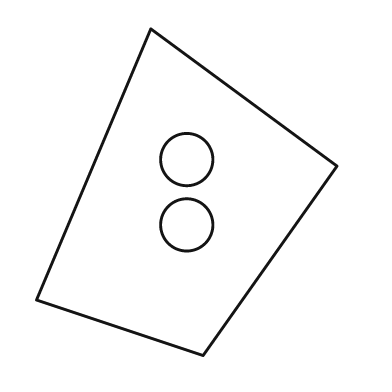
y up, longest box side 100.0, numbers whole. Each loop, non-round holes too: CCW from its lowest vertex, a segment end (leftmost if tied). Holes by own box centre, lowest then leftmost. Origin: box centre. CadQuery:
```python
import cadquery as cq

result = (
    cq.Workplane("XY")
    .moveTo(5.0, -50.0)
    .lineTo(46.0, 8.0)
    .lineTo(-11.0, 50.0)
    .lineTo(-46.0, -33.0)
    .close()
    .moveTo(0.0, -10.0)
    .circle(8.0)
    .moveTo(0.0, 10.0)
    .circle(8.0)
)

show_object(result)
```